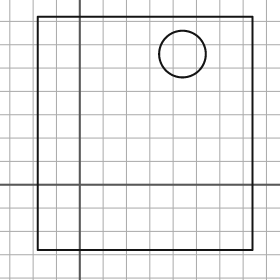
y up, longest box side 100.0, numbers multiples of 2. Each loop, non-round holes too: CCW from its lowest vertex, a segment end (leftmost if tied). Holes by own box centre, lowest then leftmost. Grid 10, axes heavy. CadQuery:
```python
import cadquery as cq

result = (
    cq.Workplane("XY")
    .moveTo(-18.0, -28.0)
    .lineTo(74.0, -28.0)
    .lineTo(74.0, 72.0)
    .lineTo(-18.0, 72.0)
    .close()
    .moveTo(44.0, 56.0)
    .circle(10.0)
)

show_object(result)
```